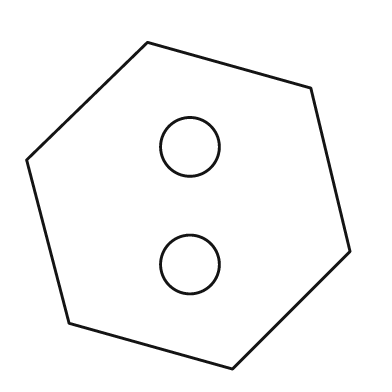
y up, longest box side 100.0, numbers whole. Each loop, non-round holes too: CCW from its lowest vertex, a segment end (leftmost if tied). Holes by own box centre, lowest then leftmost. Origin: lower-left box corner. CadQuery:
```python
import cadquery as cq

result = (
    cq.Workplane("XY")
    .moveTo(63.0, 0.0)
    .lineTo(99.0, 36.0)
    .lineTo(87.0, 86.0)
    .lineTo(37.0, 100.0)
    .lineTo(0.0, 64.0)
    .lineTo(13.0, 14.0)
    .close()
    .moveTo(50.0, 32.0)
    .circle(9.0)
    .moveTo(50.0, 68.0)
    .circle(9.0)
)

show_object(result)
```